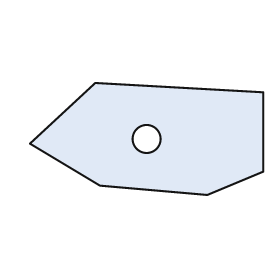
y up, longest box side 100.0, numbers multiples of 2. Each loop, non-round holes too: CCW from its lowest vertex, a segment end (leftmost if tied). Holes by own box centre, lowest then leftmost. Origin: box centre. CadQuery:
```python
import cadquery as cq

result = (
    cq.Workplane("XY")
    .moveTo(26.0, -24.0)
    .lineTo(50.0, -14.0)
    .lineTo(50.0, 20.0)
    .lineTo(-22.0, 24.0)
    .lineTo(-50.0, -2.0)
    .lineTo(-20.0, -20.0)
    .close()
    .moveTo(0.0, 0.0)
    .circle(6.0)
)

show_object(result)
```